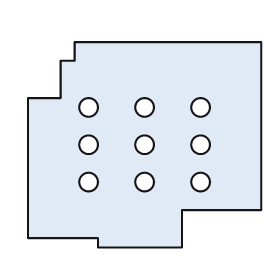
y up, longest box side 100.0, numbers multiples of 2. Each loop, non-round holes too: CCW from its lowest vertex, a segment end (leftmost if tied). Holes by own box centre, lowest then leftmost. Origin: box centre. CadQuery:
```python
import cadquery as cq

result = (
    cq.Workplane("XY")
    .moveTo(-20.0, -44.0)
    .lineTo(16.0, -44.0)
    .lineTo(16.0, -28.0)
    .lineTo(50.0, -28.0)
    .lineTo(50.0, 44.0)
    .lineTo(-30.0, 44.0)
    .lineTo(-30.0, 36.0)
    .lineTo(-36.0, 36.0)
    .lineTo(-36.0, 20.0)
    .lineTo(-50.0, 20.0)
    .lineTo(-50.0, -40.0)
    .lineTo(-20.0, -40.0)
    .close()
    .moveTo(-24.0, -16.0)
    .circle(4.0)
    .moveTo(0.0, -16.0)
    .circle(4.0)
    .moveTo(24.0, -16.0)
    .circle(4.0)
    .moveTo(-24.0, 0.0)
    .circle(4.0)
    .moveTo(0.0, 0.0)
    .circle(4.0)
    .moveTo(24.0, 0.0)
    .circle(4.0)
    .moveTo(-24.0, 16.0)
    .circle(4.0)
    .moveTo(0.0, 16.0)
    .circle(4.0)
    .moveTo(24.0, 16.0)
    .circle(4.0)
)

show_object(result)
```